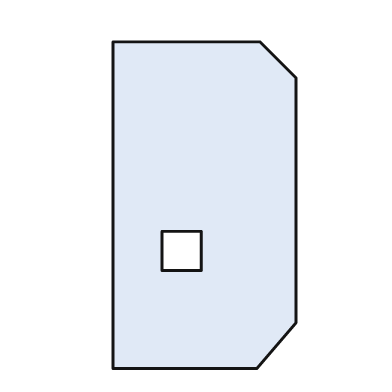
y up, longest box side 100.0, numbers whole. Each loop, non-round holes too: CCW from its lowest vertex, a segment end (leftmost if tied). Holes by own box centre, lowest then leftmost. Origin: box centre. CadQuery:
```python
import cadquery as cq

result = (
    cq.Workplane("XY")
    .moveTo(-28.0, -50.0)
    .lineTo(16.0, -50.0)
    .lineTo(28.0, -36.0)
    .lineTo(28.0, 39.0)
    .lineTo(17.0, 50.0)
    .lineTo(-28.0, 50.0)
    .close()
    .moveTo(-13.0, -20.0)
    .lineTo(-1.0, -20.0)
    .lineTo(-1.0, -8.0)
    .lineTo(-13.0, -8.0)
    .close()
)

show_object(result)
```